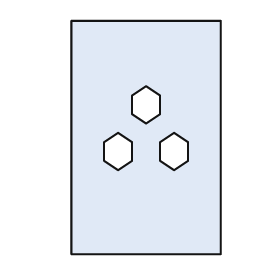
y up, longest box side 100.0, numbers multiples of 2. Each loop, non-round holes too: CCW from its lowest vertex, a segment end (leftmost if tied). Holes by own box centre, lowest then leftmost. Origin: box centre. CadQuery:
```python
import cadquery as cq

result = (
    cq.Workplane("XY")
    .moveTo(-32.0, -50.0)
    .lineTo(32.0, -50.0)
    .lineTo(32.0, 50.0)
    .lineTo(-32.0, 50.0)
    .close()
    .moveTo(-12.0, -14.0)
    .lineTo(-6.0, -10.0)
    .lineTo(-6.0, -2.0)
    .lineTo(-12.0, 2.0)
    .lineTo(-18.0, -2.0)
    .lineTo(-18.0, -10.0)
    .close()
    .moveTo(12.0, -14.0)
    .lineTo(18.0, -10.0)
    .lineTo(18.0, -2.0)
    .lineTo(12.0, 2.0)
    .lineTo(6.0, -2.0)
    .lineTo(6.0, -10.0)
    .close()
    .moveTo(0.0, 6.0)
    .lineTo(6.0, 10.0)
    .lineTo(6.0, 18.0)
    .lineTo(0.0, 22.0)
    .lineTo(-6.0, 18.0)
    .lineTo(-6.0, 10.0)
    .close()
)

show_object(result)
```